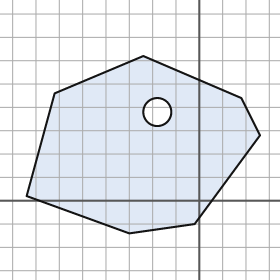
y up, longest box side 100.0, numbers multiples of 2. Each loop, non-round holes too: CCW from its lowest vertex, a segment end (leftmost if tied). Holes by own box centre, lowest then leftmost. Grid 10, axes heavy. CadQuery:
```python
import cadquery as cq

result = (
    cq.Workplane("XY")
    .moveTo(-30.0, -14.0)
    .lineTo(-2.0, -10.0)
    .lineTo(26.0, 28.0)
    .lineTo(18.0, 44.0)
    .lineTo(-24.0, 62.0)
    .lineTo(-62.0, 46.0)
    .lineTo(-74.0, 2.0)
    .close()
    .moveTo(-18.0, 38.0)
    .circle(6.0)
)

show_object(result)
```